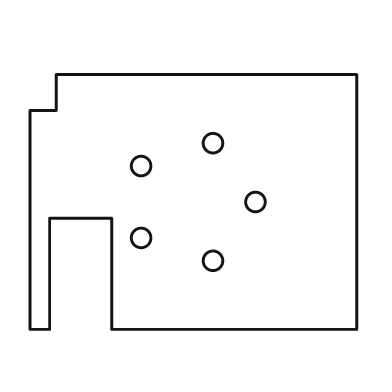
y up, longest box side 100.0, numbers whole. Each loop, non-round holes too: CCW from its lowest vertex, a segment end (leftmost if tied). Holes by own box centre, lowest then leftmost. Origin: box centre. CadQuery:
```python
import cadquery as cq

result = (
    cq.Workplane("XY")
    .moveTo(-50.0, -39.0)
    .lineTo(-44.0, -39.0)
    .lineTo(-44.0, -5.0)
    .lineTo(-25.0, -5.0)
    .lineTo(-25.0, -39.0)
    .lineTo(50.0, -39.0)
    .lineTo(50.0, 39.0)
    .lineTo(-42.0, 39.0)
    .lineTo(-42.0, 28.0)
    .lineTo(-50.0, 28.0)
    .close()
    .moveTo(6.0, -18.0)
    .circle(3.0)
    .moveTo(-16.0, -11.0)
    .circle(3.0)
    .moveTo(19.0, 0.0)
    .circle(3.0)
    .moveTo(-16.0, 11.0)
    .circle(3.0)
    .moveTo(6.0, 18.0)
    .circle(3.0)
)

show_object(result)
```